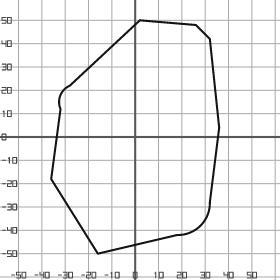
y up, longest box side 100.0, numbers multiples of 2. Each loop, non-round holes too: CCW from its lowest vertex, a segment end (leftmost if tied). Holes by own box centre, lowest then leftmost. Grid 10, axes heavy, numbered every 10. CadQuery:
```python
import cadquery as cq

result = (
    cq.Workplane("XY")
    .moveTo(-16.0, -50.0)
    .lineTo(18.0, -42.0)
    .threePointArc((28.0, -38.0), (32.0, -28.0))
    .lineTo(36.0, 4.0)
    .lineTo(32.0, 42.0)
    .lineTo(26.0, 48.0)
    .lineTo(2.0, 50.0)
    .lineTo(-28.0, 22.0)
    .threePointArc((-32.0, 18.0), (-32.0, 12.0))
    .lineTo(-36.0, -18.0)
    .close()
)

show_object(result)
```